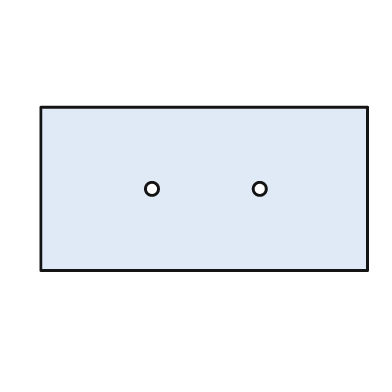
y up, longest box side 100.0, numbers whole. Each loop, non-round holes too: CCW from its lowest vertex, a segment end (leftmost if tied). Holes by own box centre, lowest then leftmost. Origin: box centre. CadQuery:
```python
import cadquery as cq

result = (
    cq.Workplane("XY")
    .moveTo(-50.0, -25.0)
    .lineTo(50.0, -25.0)
    .lineTo(50.0, 25.0)
    .lineTo(-50.0, 25.0)
    .close()
    .moveTo(-16.0, 0.0)
    .circle(2.0)
    .moveTo(17.0, 0.0)
    .circle(2.0)
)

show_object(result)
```